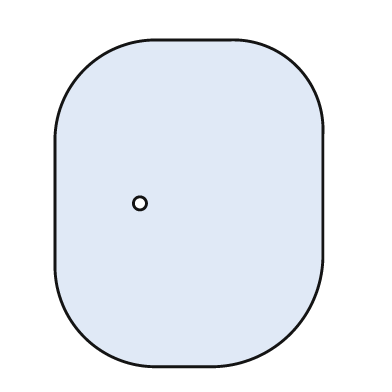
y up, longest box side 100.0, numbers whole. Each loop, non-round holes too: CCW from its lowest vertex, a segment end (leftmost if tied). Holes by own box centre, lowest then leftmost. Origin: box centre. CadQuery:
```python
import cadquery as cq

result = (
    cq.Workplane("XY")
    .moveTo(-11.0, -50.0)
    .lineTo(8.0, -50.0)
    .threePointArc((31.0, -40.0), (41.0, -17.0))
    .lineTo(41.0, 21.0)
    .threePointArc((33.0, 42.0), (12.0, 50.0))
    .lineTo(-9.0, 50.0)
    .threePointArc((-32.0, 41.0), (-41.0, 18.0))
    .lineTo(-41.0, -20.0)
    .threePointArc((-32.0, -41.0), (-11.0, -50.0))
    .close()
    .moveTo(-15.0, 0.0)
    .circle(2.0)
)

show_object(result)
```